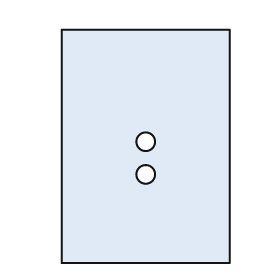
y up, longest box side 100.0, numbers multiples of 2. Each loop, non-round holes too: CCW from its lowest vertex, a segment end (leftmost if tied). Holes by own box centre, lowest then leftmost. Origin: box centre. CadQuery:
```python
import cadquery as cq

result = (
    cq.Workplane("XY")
    .moveTo(-36.0, -50.0)
    .lineTo(36.0, -50.0)
    .lineTo(36.0, 50.0)
    .lineTo(-36.0, 50.0)
    .close()
    .moveTo(0.0, -12.0)
    .circle(4.0)
    .moveTo(0.0, 2.0)
    .circle(4.0)
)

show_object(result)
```